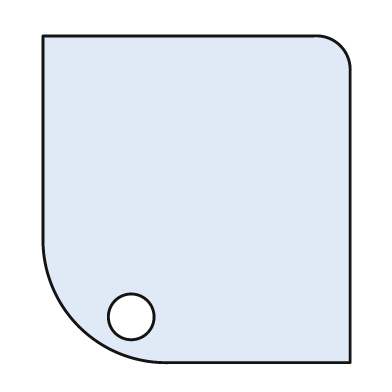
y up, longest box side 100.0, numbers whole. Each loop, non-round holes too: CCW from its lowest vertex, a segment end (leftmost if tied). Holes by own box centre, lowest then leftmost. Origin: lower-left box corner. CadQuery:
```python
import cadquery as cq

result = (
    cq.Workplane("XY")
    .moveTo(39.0, 0.0)
    .lineTo(94.0, 0.0)
    .lineTo(94.0, 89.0)
    .threePointArc((91.0, 97.0), (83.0, 100.0))
    .lineTo(0.0, 100.0)
    .lineTo(0.0, 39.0)
    .threePointArc((11.0, 11.0), (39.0, 0.0))
    .close()
    .moveTo(27.0, 14.0)
    .circle(7.0)
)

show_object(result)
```